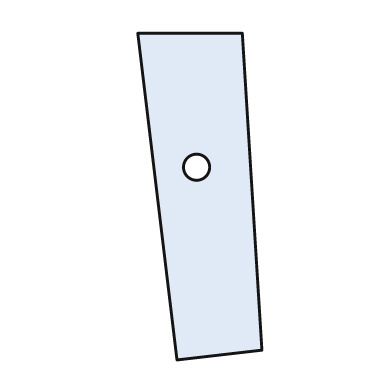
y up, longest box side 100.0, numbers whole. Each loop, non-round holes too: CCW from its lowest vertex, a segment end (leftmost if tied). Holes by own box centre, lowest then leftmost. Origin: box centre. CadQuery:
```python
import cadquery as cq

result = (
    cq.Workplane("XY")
    .moveTo(-7.0, -50.0)
    .lineTo(19.0, -47.0)
    .lineTo(13.0, 50.0)
    .lineTo(-19.0, 50.0)
    .close()
    .moveTo(-1.0, 9.0)
    .circle(4.0)
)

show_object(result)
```